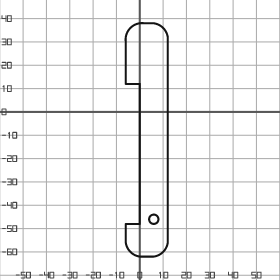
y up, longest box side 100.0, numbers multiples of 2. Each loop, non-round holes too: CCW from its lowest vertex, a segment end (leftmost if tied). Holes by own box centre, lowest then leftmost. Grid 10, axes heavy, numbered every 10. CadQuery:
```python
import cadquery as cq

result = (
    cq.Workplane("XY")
    .moveTo(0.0, -62.0)
    .lineTo(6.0, -62.0)
    .threePointArc((10.0, -60.0), (12.0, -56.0))
    .lineTo(12.0, 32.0)
    .threePointArc((10.0, 36.0), (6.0, 38.0))
    .lineTo(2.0, 38.0)
    .threePointArc((-4.0, 36.0), (-6.0, 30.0))
    .lineTo(-6.0, 12.0)
    .lineTo(0.0, 12.0)
    .lineTo(0.0, -48.0)
    .lineTo(-6.0, -48.0)
    .lineTo(-6.0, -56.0)
    .threePointArc((-4.0, -60.0), (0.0, -62.0))
    .close()
    .moveTo(6.0, -46.0)
    .circle(2.0)
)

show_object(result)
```